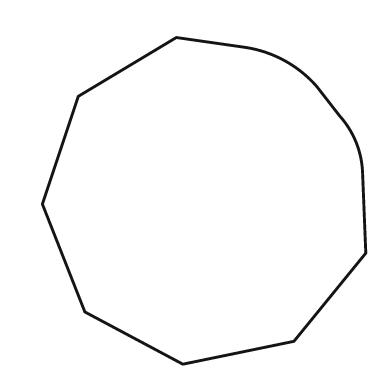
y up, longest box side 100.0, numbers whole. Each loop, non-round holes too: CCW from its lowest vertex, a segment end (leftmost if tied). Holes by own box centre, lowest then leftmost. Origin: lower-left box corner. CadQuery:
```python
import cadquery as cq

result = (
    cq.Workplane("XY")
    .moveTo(43.0, 0.0)
    .lineTo(77.0, 7.0)
    .lineTo(99.0, 34.0)
    .lineTo(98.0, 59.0)
    .threePointArc((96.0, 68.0), (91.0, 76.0))
    .lineTo(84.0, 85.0)
    .threePointArc((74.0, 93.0), (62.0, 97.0))
    .lineTo(41.0, 100.0)
    .lineTo(11.0, 82.0)
    .lineTo(0.0, 49.0)
    .lineTo(13.0, 16.0)
    .close()
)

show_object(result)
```